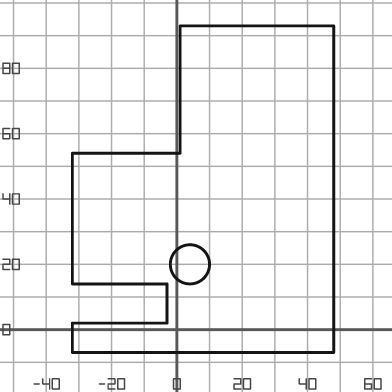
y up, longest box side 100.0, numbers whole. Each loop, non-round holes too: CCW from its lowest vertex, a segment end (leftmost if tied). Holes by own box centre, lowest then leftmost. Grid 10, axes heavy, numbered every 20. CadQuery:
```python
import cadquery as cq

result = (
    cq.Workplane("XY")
    .moveTo(-32.0, -7.0)
    .lineTo(48.0, -7.0)
    .lineTo(48.0, 93.0)
    .lineTo(1.0, 93.0)
    .lineTo(1.0, 54.0)
    .lineTo(-32.0, 54.0)
    .lineTo(-32.0, 14.0)
    .lineTo(-3.0, 14.0)
    .lineTo(-3.0, 2.0)
    .lineTo(-32.0, 2.0)
    .close()
    .moveTo(4.0, 20.0)
    .circle(6.0)
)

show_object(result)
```